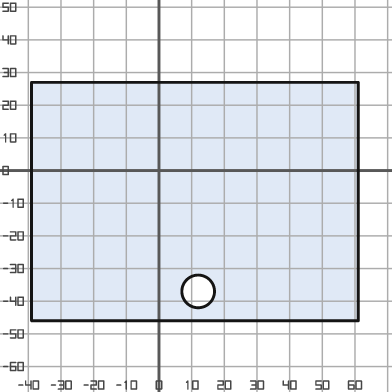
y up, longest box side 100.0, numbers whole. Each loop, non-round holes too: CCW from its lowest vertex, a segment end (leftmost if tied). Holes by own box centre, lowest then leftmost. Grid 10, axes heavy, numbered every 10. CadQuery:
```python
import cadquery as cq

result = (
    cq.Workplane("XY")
    .moveTo(-39.0, -46.0)
    .lineTo(61.0, -46.0)
    .lineTo(61.0, 27.0)
    .lineTo(-39.0, 27.0)
    .close()
    .moveTo(12.0, -37.0)
    .circle(5.0)
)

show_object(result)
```